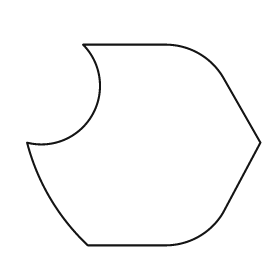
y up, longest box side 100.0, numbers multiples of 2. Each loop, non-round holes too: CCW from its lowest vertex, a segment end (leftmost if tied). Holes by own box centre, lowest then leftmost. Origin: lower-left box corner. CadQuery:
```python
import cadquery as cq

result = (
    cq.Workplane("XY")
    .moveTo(26.0, 0.0)
    .lineTo(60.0, 0.0)
    .threePointArc((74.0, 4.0), (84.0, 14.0))
    .lineTo(100.0, 44.0)
    .lineTo(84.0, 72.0)
    .threePointArc((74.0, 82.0), (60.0, 86.0))
    .lineTo(24.0, 86.0)
    .threePointArc((28.0, 56.0), (0.0, 44.0))
    .threePointArc((10.0, 20.0), (26.0, 0.0))
    .close()
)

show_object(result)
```